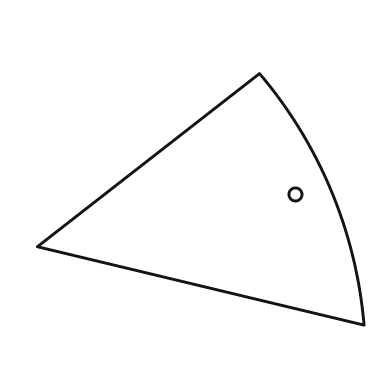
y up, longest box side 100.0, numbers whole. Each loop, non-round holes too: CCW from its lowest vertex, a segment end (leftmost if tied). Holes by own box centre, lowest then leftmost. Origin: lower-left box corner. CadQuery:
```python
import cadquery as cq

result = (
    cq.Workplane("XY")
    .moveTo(100.0, 0.0)
    .threePointArc((90.0, 41.0), (68.0, 77.0))
    .lineTo(0.0, 24.0)
    .close()
    .moveTo(79.0, 40.0)
    .circle(2.0)
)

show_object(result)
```